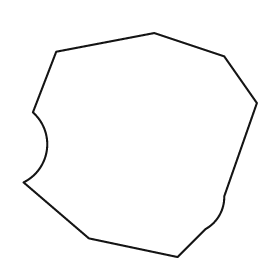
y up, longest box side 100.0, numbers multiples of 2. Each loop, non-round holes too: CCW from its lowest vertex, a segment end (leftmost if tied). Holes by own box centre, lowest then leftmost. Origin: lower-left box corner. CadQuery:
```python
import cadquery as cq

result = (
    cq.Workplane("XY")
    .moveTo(66.0, 0.0)
    .lineTo(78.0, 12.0)
    .threePointArc((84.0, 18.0), (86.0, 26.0))
    .lineTo(100.0, 66.0)
    .lineTo(86.0, 86.0)
    .lineTo(56.0, 96.0)
    .lineTo(14.0, 88.0)
    .lineTo(4.0, 62.0)
    .threePointArc((10.0, 46.0), (0.0, 32.0))
    .lineTo(28.0, 8.0)
    .close()
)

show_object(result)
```